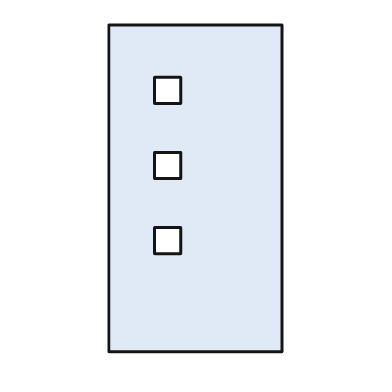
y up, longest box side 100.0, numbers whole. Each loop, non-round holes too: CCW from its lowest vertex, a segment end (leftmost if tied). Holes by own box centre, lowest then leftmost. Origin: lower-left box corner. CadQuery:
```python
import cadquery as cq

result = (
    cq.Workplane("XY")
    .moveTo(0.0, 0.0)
    .lineTo(53.0, 0.0)
    .lineTo(53.0, 100.0)
    .lineTo(0.0, 100.0)
    .close()
    .moveTo(14.0, 30.0)
    .lineTo(22.0, 30.0)
    .lineTo(22.0, 38.0)
    .lineTo(14.0, 38.0)
    .close()
    .moveTo(14.0, 53.0)
    .lineTo(22.0, 53.0)
    .lineTo(22.0, 61.0)
    .lineTo(14.0, 61.0)
    .close()
    .moveTo(14.0, 76.0)
    .lineTo(22.0, 76.0)
    .lineTo(22.0, 84.0)
    .lineTo(14.0, 84.0)
    .close()
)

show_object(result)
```